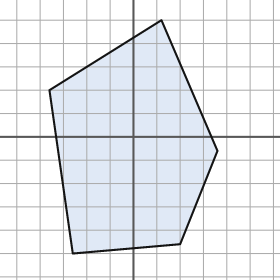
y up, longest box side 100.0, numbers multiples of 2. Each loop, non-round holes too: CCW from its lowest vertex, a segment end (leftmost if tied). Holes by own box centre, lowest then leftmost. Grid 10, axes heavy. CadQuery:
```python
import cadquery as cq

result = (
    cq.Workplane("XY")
    .moveTo(-26.0, -50.0)
    .lineTo(20.0, -46.0)
    .lineTo(36.0, -6.0)
    .lineTo(12.0, 50.0)
    .lineTo(-36.0, 20.0)
    .close()
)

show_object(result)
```